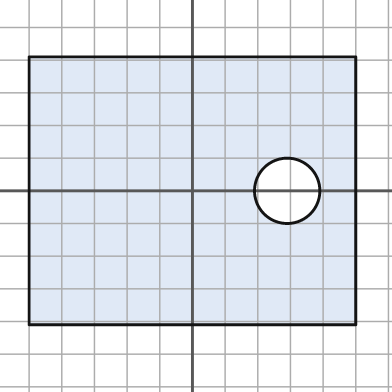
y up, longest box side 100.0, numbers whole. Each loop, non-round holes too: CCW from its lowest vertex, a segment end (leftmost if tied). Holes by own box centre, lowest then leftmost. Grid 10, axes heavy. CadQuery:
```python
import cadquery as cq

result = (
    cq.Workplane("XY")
    .moveTo(-50.0, -41.0)
    .lineTo(50.0, -41.0)
    .lineTo(50.0, 41.0)
    .lineTo(-50.0, 41.0)
    .close()
    .moveTo(29.0, 0.0)
    .circle(10.0)
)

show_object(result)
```